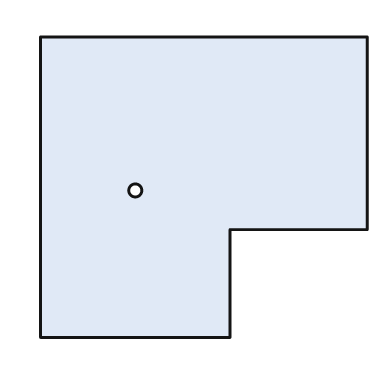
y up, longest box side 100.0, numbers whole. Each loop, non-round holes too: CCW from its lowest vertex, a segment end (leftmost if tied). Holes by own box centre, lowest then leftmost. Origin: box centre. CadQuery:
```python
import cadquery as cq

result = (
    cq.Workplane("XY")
    .moveTo(-50.0, -46.0)
    .lineTo(8.0, -46.0)
    .lineTo(8.0, -13.0)
    .lineTo(50.0, -13.0)
    .lineTo(50.0, 46.0)
    .lineTo(-50.0, 46.0)
    .close()
    .moveTo(-21.0, -1.0)
    .circle(2.0)
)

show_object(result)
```